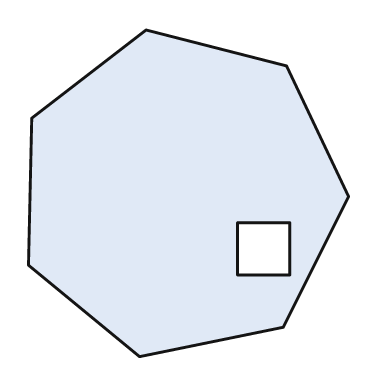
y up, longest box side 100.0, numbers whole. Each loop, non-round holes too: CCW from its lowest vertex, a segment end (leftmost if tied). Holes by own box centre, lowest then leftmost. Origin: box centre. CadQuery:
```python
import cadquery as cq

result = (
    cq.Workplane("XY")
    .moveTo(-15.0, -50.0)
    .lineTo(29.0, -41.0)
    .lineTo(49.0, -1.0)
    .lineTo(30.0, 39.0)
    .lineTo(-13.0, 50.0)
    .lineTo(-48.0, 23.0)
    .lineTo(-49.0, -22.0)
    .close()
    .moveTo(15.0, -25.0)
    .lineTo(31.0, -25.0)
    .lineTo(31.0, -9.0)
    .lineTo(15.0, -9.0)
    .close()
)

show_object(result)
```